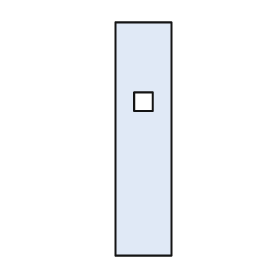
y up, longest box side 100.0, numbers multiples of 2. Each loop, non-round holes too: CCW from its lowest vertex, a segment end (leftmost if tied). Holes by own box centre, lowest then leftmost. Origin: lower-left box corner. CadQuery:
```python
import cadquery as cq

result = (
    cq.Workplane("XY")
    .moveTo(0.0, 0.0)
    .lineTo(24.0, 0.0)
    .lineTo(24.0, 100.0)
    .lineTo(0.0, 100.0)
    .close()
    .moveTo(8.0, 62.0)
    .lineTo(16.0, 62.0)
    .lineTo(16.0, 70.0)
    .lineTo(8.0, 70.0)
    .close()
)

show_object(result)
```